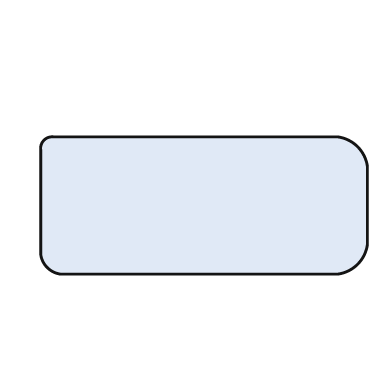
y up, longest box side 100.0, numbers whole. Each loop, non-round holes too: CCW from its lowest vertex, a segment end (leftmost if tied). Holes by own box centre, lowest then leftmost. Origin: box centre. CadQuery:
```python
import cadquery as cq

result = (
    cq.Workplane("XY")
    .moveTo(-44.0, -21.0)
    .lineTo(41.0, -21.0)
    .threePointArc((47.0, -18.0), (50.0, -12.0))
    .lineTo(50.0, 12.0)
    .threePointArc((47.0, 18.0), (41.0, 21.0))
    .lineTo(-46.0, 21.0)
    .threePointArc((-49.0, 20.0), (-50.0, 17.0))
    .lineTo(-50.0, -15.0)
    .threePointArc((-48.0, -19.0), (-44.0, -21.0))
    .close()
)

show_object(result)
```